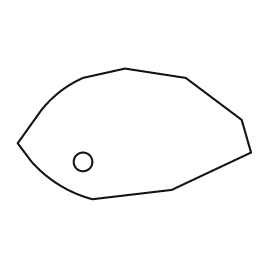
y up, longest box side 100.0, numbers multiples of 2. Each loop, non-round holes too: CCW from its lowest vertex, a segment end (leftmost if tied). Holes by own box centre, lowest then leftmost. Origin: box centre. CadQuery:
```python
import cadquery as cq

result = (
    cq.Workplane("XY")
    .moveTo(-18.0, -28.0)
    .lineTo(16.0, -24.0)
    .lineTo(50.0, -8.0)
    .lineTo(46.0, 6.0)
    .lineTo(22.0, 24.0)
    .lineTo(-4.0, 28.0)
    .lineTo(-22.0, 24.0)
    .threePointArc((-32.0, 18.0), (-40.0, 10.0))
    .lineTo(-50.0, -4.0)
    .lineTo(-44.0, -12.0)
    .threePointArc((-32.0, -22.0), (-18.0, -28.0))
    .close()
    .moveTo(-22.0, -12.0)
    .circle(4.0)
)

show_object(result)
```